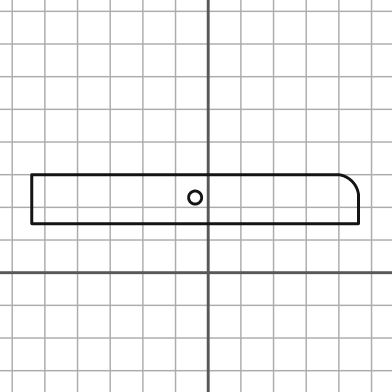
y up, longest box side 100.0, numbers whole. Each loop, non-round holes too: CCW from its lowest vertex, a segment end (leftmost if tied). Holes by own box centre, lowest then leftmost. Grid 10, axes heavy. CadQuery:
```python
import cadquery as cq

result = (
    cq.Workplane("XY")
    .moveTo(-54.0, 15.0)
    .lineTo(46.0, 15.0)
    .lineTo(46.0, 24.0)
    .threePointArc((44.0, 28.0), (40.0, 30.0))
    .lineTo(-54.0, 30.0)
    .close()
    .moveTo(-4.0, 23.0)
    .circle(2.0)
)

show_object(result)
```